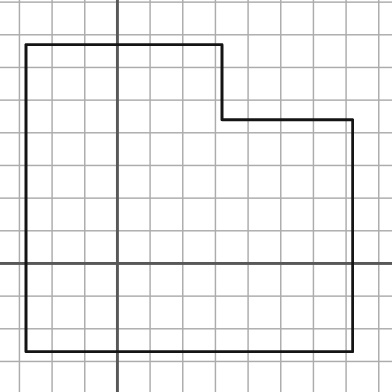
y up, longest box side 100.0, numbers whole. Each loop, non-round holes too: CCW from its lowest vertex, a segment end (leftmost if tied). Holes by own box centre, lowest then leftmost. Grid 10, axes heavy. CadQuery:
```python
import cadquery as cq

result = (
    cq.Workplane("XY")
    .moveTo(-28.0, -27.0)
    .lineTo(72.0, -27.0)
    .lineTo(72.0, 44.0)
    .lineTo(32.0, 44.0)
    .lineTo(32.0, 67.0)
    .lineTo(-28.0, 67.0)
    .close()
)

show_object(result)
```